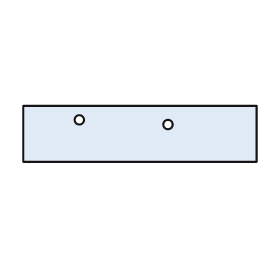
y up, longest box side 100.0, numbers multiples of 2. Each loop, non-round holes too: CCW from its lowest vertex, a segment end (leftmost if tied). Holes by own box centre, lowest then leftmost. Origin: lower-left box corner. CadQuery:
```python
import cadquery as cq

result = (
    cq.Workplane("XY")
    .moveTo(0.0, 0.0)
    .lineTo(100.0, 0.0)
    .lineTo(100.0, 24.0)
    .lineTo(0.0, 24.0)
    .close()
    .moveTo(62.0, 16.0)
    .circle(2.0)
    .moveTo(24.0, 18.0)
    .circle(2.0)
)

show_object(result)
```